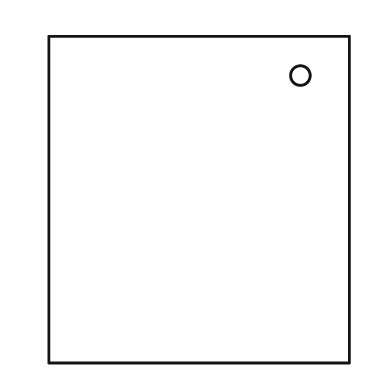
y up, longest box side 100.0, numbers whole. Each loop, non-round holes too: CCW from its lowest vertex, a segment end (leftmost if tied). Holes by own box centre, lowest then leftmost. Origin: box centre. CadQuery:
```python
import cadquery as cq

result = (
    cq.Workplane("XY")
    .moveTo(-46.0, -50.0)
    .lineTo(46.0, -50.0)
    .lineTo(46.0, 50.0)
    .lineTo(-46.0, 50.0)
    .close()
    .moveTo(31.0, 38.0)
    .circle(3.0)
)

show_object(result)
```